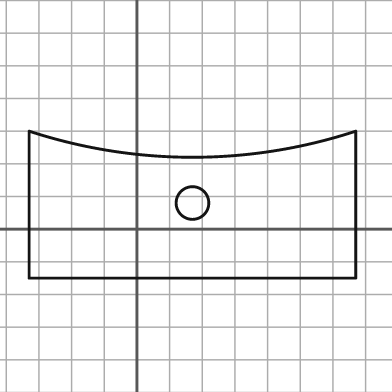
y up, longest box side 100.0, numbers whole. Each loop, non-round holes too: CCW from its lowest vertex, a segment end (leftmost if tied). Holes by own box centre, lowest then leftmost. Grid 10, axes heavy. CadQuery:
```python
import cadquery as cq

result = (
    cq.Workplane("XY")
    .moveTo(-33.0, -15.0)
    .lineTo(67.0, -15.0)
    .lineTo(67.0, 30.0)
    .threePointArc((17.0, 22.0), (-33.0, 30.0))
    .close()
    .moveTo(17.0, 8.0)
    .circle(5.0)
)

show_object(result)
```